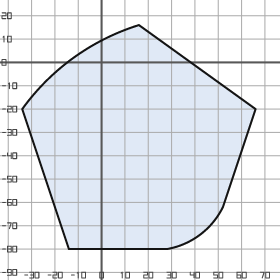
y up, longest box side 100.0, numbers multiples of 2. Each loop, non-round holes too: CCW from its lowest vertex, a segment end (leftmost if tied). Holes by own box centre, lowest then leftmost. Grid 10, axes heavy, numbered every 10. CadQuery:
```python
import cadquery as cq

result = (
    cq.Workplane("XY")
    .moveTo(-14.0, -80.0)
    .lineTo(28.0, -80.0)
    .threePointArc((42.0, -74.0), (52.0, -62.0))
    .lineTo(66.0, -20.0)
    .lineTo(16.0, 16.0)
    .threePointArc((-12.0, 2.0), (-34.0, -20.0))
    .close()
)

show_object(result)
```